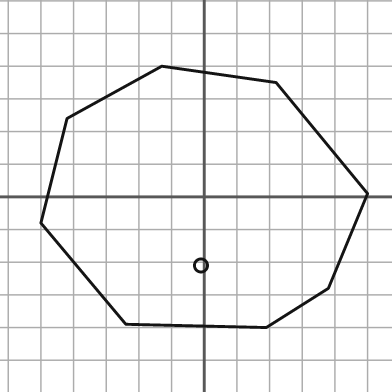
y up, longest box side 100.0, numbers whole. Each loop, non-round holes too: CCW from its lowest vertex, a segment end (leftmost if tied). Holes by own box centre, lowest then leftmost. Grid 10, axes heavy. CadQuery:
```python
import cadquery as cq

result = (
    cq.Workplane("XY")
    .moveTo(19.0, -40.0)
    .lineTo(38.0, -28.0)
    .lineTo(50.0, 1.0)
    .lineTo(22.0, 35.0)
    .lineTo(-13.0, 40.0)
    .lineTo(-42.0, 24.0)
    .lineTo(-50.0, -8.0)
    .lineTo(-24.0, -39.0)
    .close()
    .moveTo(-1.0, -21.0)
    .circle(2.0)
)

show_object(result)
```